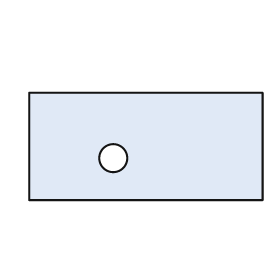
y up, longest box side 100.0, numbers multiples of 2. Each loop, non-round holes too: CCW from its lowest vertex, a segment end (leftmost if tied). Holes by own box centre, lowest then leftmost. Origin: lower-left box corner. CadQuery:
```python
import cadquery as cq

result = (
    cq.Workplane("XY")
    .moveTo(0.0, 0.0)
    .lineTo(100.0, 0.0)
    .lineTo(100.0, 46.0)
    .lineTo(0.0, 46.0)
    .close()
    .moveTo(36.0, 18.0)
    .circle(6.0)
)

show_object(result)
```